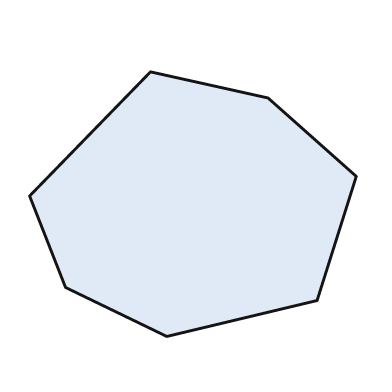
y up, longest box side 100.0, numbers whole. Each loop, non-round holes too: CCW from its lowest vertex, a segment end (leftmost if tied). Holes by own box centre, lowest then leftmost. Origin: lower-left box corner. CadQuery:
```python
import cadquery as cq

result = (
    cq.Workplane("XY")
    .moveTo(42.0, 0.0)
    .lineTo(88.0, 11.0)
    .lineTo(100.0, 49.0)
    .lineTo(73.0, 73.0)
    .lineTo(37.0, 81.0)
    .lineTo(0.0, 43.0)
    .lineTo(11.0, 15.0)
    .close()
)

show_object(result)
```